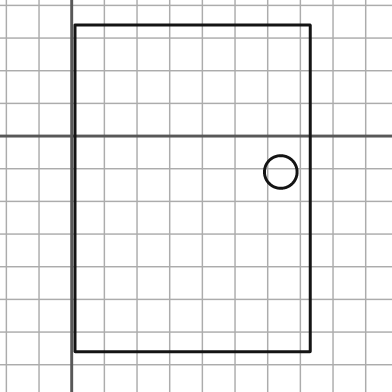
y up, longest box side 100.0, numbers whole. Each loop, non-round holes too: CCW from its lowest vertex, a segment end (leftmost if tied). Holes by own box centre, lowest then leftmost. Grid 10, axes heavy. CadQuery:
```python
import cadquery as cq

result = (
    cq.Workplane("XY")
    .moveTo(1.0, -66.0)
    .lineTo(73.0, -66.0)
    .lineTo(73.0, 34.0)
    .lineTo(1.0, 34.0)
    .close()
    .moveTo(64.0, -11.0)
    .circle(5.0)
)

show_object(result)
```